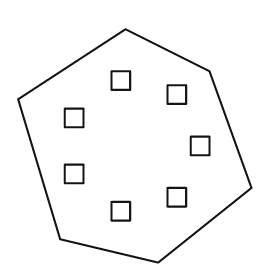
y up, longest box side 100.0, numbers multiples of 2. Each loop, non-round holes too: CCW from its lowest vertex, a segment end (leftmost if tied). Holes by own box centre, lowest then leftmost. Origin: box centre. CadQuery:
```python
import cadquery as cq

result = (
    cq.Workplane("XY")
    .moveTo(10.0, -50.0)
    .lineTo(50.0, -18.0)
    .lineTo(32.0, 32.0)
    .lineTo(-4.0, 50.0)
    .lineTo(-50.0, 20.0)
    .lineTo(-32.0, -40.0)
    .close()
    .moveTo(-10.0, -32.0)
    .lineTo(-2.0, -32.0)
    .lineTo(-2.0, -24.0)
    .lineTo(-10.0, -24.0)
    .close()
    .moveTo(14.0, -26.0)
    .lineTo(22.0, -26.0)
    .lineTo(22.0, -18.0)
    .lineTo(14.0, -18.0)
    .close()
    .moveTo(-30.0, -16.0)
    .lineTo(-22.0, -16.0)
    .lineTo(-22.0, -8.0)
    .lineTo(-30.0, -8.0)
    .close()
    .moveTo(24.0, -4.0)
    .lineTo(32.0, -4.0)
    .lineTo(32.0, 4.0)
    .lineTo(24.0, 4.0)
    .close()
    .moveTo(-30.0, 8.0)
    .lineTo(-22.0, 8.0)
    .lineTo(-22.0, 16.0)
    .lineTo(-30.0, 16.0)
    .close()
    .moveTo(14.0, 18.0)
    .lineTo(22.0, 18.0)
    .lineTo(22.0, 26.0)
    .lineTo(14.0, 26.0)
    .close()
    .moveTo(-10.0, 24.0)
    .lineTo(-2.0, 24.0)
    .lineTo(-2.0, 32.0)
    .lineTo(-10.0, 32.0)
    .close()
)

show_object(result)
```